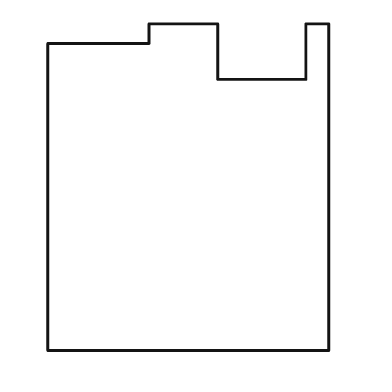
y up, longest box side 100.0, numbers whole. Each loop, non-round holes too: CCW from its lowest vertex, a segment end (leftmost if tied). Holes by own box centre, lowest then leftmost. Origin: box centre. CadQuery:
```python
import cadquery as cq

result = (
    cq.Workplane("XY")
    .moveTo(-43.0, -50.0)
    .lineTo(43.0, -50.0)
    .lineTo(43.0, 50.0)
    .lineTo(36.0, 50.0)
    .lineTo(36.0, 33.0)
    .lineTo(9.0, 33.0)
    .lineTo(9.0, 50.0)
    .lineTo(-12.0, 50.0)
    .lineTo(-12.0, 44.0)
    .lineTo(-43.0, 44.0)
    .close()
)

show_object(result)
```